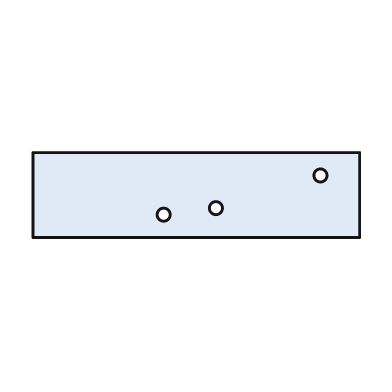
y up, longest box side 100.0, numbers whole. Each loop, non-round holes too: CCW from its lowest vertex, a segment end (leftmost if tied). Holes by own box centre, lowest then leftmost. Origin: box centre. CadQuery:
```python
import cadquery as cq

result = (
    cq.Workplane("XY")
    .moveTo(-50.0, -13.0)
    .lineTo(50.0, -13.0)
    .lineTo(50.0, 13.0)
    .lineTo(-50.0, 13.0)
    .close()
    .moveTo(-10.0, -6.0)
    .circle(2.0)
    .moveTo(6.0, -4.0)
    .circle(2.0)
    .moveTo(38.0, 6.0)
    .circle(2.0)
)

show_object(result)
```